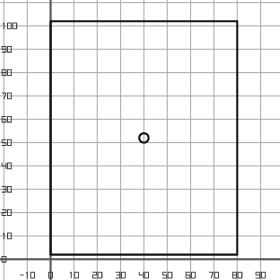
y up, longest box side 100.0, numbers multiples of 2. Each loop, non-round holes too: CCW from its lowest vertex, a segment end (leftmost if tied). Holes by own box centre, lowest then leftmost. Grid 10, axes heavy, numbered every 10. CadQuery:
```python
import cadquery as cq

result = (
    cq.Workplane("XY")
    .moveTo(0.0, 2.0)
    .lineTo(80.0, 2.0)
    .lineTo(80.0, 102.0)
    .lineTo(0.0, 102.0)
    .close()
    .moveTo(40.0, 52.0)
    .circle(2.0)
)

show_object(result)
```